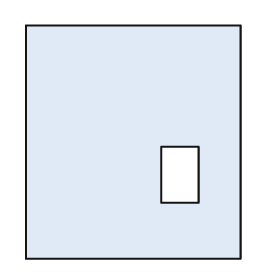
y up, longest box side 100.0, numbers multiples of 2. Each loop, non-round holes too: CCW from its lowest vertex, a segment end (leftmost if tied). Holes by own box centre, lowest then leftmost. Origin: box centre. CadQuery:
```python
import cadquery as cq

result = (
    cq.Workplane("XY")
    .moveTo(-46.0, -50.0)
    .lineTo(46.0, -50.0)
    .lineTo(46.0, 50.0)
    .lineTo(-46.0, 50.0)
    .close()
    .moveTo(12.0, -26.0)
    .lineTo(28.0, -26.0)
    .lineTo(28.0, -2.0)
    .lineTo(12.0, -2.0)
    .close()
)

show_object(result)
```